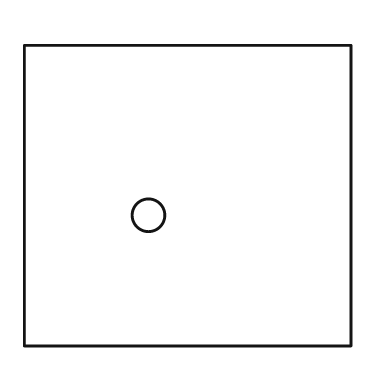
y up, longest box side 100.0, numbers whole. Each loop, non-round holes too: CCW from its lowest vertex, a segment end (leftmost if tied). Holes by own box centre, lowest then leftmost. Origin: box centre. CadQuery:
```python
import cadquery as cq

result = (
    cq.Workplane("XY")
    .moveTo(-50.0, -46.0)
    .lineTo(50.0, -46.0)
    .lineTo(50.0, 46.0)
    .lineTo(-50.0, 46.0)
    .close()
    .moveTo(-12.0, -6.0)
    .circle(5.0)
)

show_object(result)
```